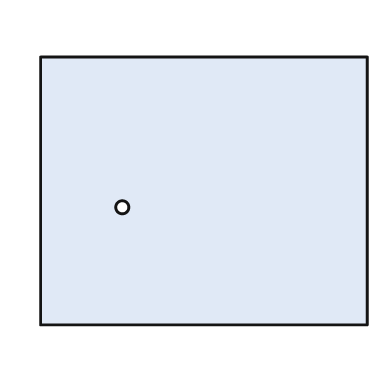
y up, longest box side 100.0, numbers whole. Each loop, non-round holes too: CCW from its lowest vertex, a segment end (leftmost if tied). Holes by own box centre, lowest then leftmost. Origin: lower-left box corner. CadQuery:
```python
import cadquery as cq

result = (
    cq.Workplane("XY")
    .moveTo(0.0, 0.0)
    .lineTo(100.0, 0.0)
    .lineTo(100.0, 82.0)
    .lineTo(0.0, 82.0)
    .close()
    .moveTo(25.0, 36.0)
    .circle(2.0)
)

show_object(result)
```